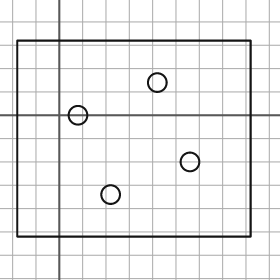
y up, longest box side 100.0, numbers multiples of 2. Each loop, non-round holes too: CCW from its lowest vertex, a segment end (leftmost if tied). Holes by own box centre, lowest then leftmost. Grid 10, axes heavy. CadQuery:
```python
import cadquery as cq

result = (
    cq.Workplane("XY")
    .moveTo(-18.0, -52.0)
    .lineTo(82.0, -52.0)
    .lineTo(82.0, 32.0)
    .lineTo(-18.0, 32.0)
    .close()
    .moveTo(22.0, -34.0)
    .circle(4.0)
    .moveTo(56.0, -20.0)
    .circle(4.0)
    .moveTo(8.0, 0.0)
    .circle(4.0)
    .moveTo(42.0, 14.0)
    .circle(4.0)
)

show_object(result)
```